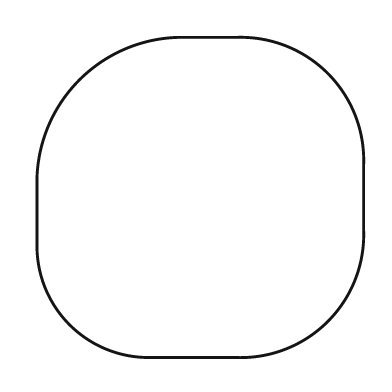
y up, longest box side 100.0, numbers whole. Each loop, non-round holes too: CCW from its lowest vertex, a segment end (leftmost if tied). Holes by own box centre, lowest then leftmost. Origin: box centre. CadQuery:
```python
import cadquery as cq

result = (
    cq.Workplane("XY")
    .moveTo(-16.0, -49.0)
    .lineTo(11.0, -49.0)
    .threePointArc((39.0, -38.0), (50.0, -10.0))
    .lineTo(50.0, 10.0)
    .threePointArc((39.0, 38.0), (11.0, 49.0))
    .lineTo(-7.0, 49.0)
    .threePointArc((-37.0, 36.0), (-50.0, 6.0))
    .lineTo(-50.0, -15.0)
    .threePointArc((-40.0, -39.0), (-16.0, -49.0))
    .close()
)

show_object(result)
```